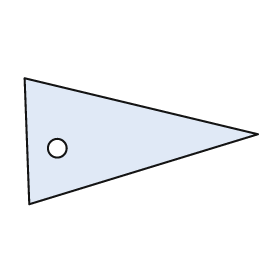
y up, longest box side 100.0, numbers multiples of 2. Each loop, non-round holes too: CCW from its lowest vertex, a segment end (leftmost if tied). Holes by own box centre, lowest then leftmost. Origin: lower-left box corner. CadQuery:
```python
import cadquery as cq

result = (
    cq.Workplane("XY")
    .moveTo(2.0, 0.0)
    .lineTo(100.0, 30.0)
    .lineTo(0.0, 54.0)
    .close()
    .moveTo(14.0, 24.0)
    .circle(4.0)
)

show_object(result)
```